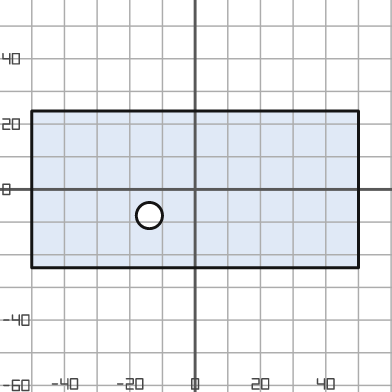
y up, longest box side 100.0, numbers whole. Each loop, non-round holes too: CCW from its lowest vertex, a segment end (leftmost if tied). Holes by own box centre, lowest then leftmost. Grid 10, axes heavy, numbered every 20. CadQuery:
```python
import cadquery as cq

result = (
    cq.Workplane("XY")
    .moveTo(-50.0, -24.0)
    .lineTo(50.0, -24.0)
    .lineTo(50.0, 24.0)
    .lineTo(-50.0, 24.0)
    .close()
    .moveTo(-14.0, -8.0)
    .circle(4.0)
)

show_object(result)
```